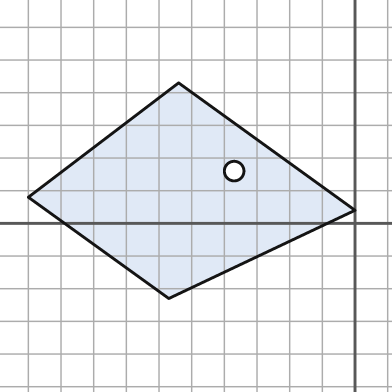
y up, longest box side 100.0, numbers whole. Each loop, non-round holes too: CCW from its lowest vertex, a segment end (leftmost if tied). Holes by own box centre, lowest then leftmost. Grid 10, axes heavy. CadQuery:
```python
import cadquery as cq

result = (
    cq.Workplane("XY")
    .moveTo(-57.0, -23.0)
    .lineTo(0.0, 4.0)
    .lineTo(-54.0, 43.0)
    .lineTo(-100.0, 8.0)
    .close()
    .moveTo(-37.0, 16.0)
    .circle(3.0)
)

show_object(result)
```